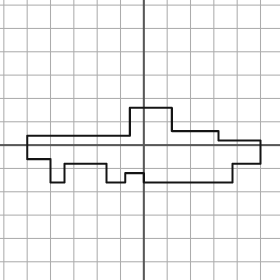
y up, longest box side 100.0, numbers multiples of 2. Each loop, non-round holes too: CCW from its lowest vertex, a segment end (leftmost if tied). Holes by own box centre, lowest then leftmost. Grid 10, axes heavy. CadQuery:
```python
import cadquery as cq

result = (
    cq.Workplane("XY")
    .moveTo(-40.0, -16.0)
    .lineTo(-34.0, -16.0)
    .lineTo(-34.0, -8.0)
    .lineTo(-16.0, -8.0)
    .lineTo(-16.0, -16.0)
    .lineTo(-8.0, -16.0)
    .lineTo(-8.0, -12.0)
    .lineTo(0.0, -12.0)
    .lineTo(0.0, -16.0)
    .lineTo(38.0, -16.0)
    .lineTo(38.0, -8.0)
    .lineTo(50.0, -8.0)
    .lineTo(50.0, 2.0)
    .lineTo(32.0, 2.0)
    .lineTo(32.0, 6.0)
    .lineTo(12.0, 6.0)
    .lineTo(12.0, 16.0)
    .lineTo(-6.0, 16.0)
    .lineTo(-6.0, 4.0)
    .lineTo(-50.0, 4.0)
    .lineTo(-50.0, -6.0)
    .lineTo(-40.0, -6.0)
    .close()
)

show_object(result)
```